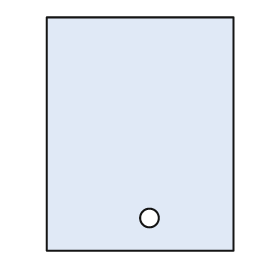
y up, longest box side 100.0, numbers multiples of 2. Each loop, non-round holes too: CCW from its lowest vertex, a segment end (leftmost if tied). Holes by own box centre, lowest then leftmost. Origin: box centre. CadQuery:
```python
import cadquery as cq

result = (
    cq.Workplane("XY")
    .moveTo(-40.0, -50.0)
    .lineTo(40.0, -50.0)
    .lineTo(40.0, 50.0)
    .lineTo(-40.0, 50.0)
    .close()
    .moveTo(4.0, -36.0)
    .circle(4.0)
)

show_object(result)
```